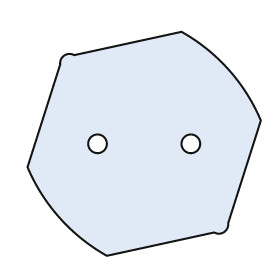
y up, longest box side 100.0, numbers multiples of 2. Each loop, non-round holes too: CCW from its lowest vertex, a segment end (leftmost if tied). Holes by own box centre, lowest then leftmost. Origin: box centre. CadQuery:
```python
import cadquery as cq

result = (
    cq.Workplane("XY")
    .moveTo(-16.0, -48.0)
    .lineTo(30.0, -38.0)
    .threePointArc((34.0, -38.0), (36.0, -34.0))
    .lineTo(50.0, 10.0)
    .threePointArc((36.0, 32.0), (16.0, 48.0))
    .lineTo(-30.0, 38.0)
    .threePointArc((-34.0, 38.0), (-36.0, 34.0))
    .lineTo(-50.0, -10.0)
    .threePointArc((-36.0, -32.0), (-16.0, -48.0))
    .close()
    .moveTo(-20.0, 0.0)
    .circle(4.0)
    .moveTo(20.0, 0.0)
    .circle(4.0)
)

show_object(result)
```